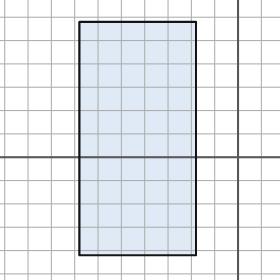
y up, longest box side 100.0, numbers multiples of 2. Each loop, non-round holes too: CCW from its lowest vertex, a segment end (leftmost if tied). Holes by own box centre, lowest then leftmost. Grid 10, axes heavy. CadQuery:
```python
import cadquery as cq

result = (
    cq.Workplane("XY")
    .moveTo(-68.0, -42.0)
    .lineTo(-18.0, -42.0)
    .lineTo(-18.0, 58.0)
    .lineTo(-68.0, 58.0)
    .close()
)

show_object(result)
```